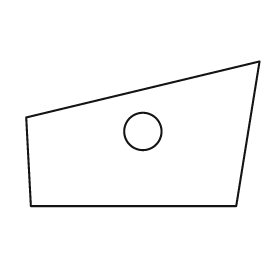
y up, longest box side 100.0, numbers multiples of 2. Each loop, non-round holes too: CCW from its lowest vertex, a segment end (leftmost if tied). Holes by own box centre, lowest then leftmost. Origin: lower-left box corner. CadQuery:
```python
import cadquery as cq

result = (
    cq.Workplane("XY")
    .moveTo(2.0, 0.0)
    .lineTo(90.0, 0.0)
    .lineTo(100.0, 62.0)
    .lineTo(0.0, 38.0)
    .close()
    .moveTo(50.0, 32.0)
    .circle(8.0)
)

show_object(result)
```